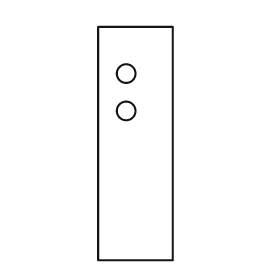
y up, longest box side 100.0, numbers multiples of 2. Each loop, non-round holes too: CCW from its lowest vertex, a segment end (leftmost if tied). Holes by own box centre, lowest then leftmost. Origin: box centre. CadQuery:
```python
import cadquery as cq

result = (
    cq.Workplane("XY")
    .moveTo(-16.0, -50.0)
    .lineTo(16.0, -50.0)
    .lineTo(16.0, 50.0)
    .lineTo(-16.0, 50.0)
    .close()
    .moveTo(-4.0, 14.0)
    .circle(4.0)
    .moveTo(-4.0, 30.0)
    .circle(4.0)
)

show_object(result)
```